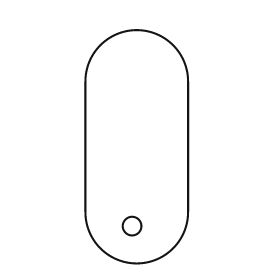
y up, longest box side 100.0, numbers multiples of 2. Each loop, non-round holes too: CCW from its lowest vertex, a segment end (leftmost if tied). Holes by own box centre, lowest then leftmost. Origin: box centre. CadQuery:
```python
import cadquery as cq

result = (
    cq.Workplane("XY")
    .moveTo(-22.0, -28.0)
    .threePointArc((0.0, -50.0), (22.0, -28.0))
    .lineTo(22.0, 28.0)
    .threePointArc((0.0, 50.0), (-22.0, 28.0))
    .close()
    .moveTo(-2.0, -34.0)
    .circle(4.0)
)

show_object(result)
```